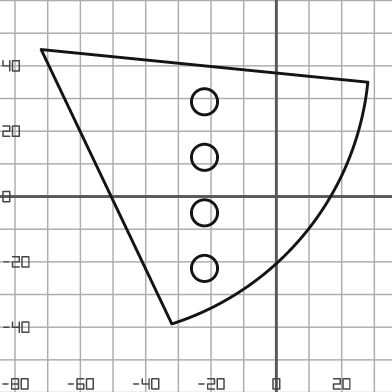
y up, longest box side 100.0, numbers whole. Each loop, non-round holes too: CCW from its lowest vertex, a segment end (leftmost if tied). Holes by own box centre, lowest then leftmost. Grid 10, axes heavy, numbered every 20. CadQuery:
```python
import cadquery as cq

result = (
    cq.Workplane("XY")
    .moveTo(-32.0, -39.0)
    .threePointArc((9.0, -11.0), (28.0, 35.0))
    .lineTo(-72.0, 45.0)
    .close()
    .moveTo(-22.0, -22.0)
    .circle(4.0)
    .moveTo(-22.0, -5.0)
    .circle(4.0)
    .moveTo(-22.0, 12.0)
    .circle(4.0)
    .moveTo(-22.0, 29.0)
    .circle(4.0)
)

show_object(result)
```